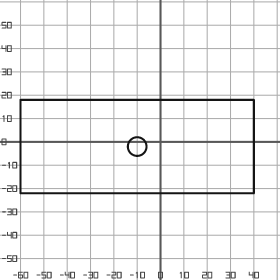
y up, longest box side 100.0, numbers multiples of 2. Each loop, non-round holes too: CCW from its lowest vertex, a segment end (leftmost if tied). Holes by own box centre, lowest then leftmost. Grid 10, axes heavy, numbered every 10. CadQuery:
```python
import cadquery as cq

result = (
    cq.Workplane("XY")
    .moveTo(-60.0, -22.0)
    .lineTo(40.0, -22.0)
    .lineTo(40.0, 18.0)
    .lineTo(-60.0, 18.0)
    .close()
    .moveTo(-10.0, -2.0)
    .circle(4.0)
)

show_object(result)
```